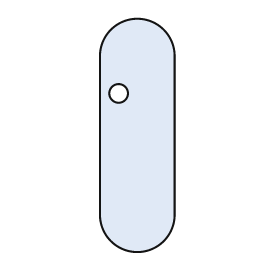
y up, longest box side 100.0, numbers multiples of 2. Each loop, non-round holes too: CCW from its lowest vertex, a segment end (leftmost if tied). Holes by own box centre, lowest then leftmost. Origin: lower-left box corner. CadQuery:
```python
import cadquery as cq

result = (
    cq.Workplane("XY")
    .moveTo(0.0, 16.0)
    .threePointArc((16.0, 0.0), (32.0, 16.0))
    .lineTo(32.0, 84.0)
    .threePointArc((16.0, 100.0), (0.0, 84.0))
    .close()
    .moveTo(8.0, 68.0)
    .circle(4.0)
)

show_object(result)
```